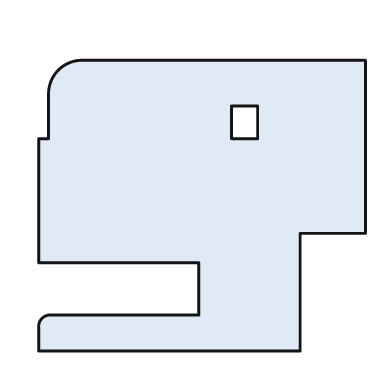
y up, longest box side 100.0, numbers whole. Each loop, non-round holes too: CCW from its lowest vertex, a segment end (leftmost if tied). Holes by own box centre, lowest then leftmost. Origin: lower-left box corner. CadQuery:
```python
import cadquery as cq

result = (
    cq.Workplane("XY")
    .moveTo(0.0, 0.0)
    .lineTo(80.0, 0.0)
    .lineTo(80.0, 36.0)
    .lineTo(100.0, 36.0)
    .lineTo(100.0, 89.0)
    .lineTo(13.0, 89.0)
    .threePointArc((6.0, 86.0), (3.0, 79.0))
    .lineTo(3.0, 65.0)
    .lineTo(0.0, 65.0)
    .lineTo(0.0, 27.0)
    .lineTo(49.0, 27.0)
    .lineTo(49.0, 11.0)
    .lineTo(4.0, 11.0)
    .threePointArc((1.0, 10.0), (0.0, 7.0))
    .close()
    .moveTo(59.0, 65.0)
    .lineTo(67.0, 65.0)
    .lineTo(67.0, 75.0)
    .lineTo(59.0, 75.0)
    .close()
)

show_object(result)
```